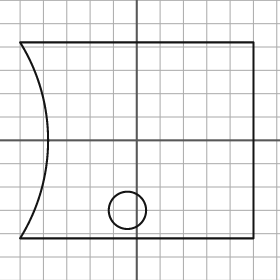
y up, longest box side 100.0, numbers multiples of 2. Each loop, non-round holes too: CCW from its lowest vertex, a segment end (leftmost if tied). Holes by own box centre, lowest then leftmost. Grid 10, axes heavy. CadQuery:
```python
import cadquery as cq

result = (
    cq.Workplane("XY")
    .moveTo(-50.0, -42.0)
    .lineTo(50.0, -42.0)
    .lineTo(50.0, 42.0)
    .lineTo(-50.0, 42.0)
    .threePointArc((-38.0, 0.0), (-50.0, -42.0))
    .close()
    .moveTo(-4.0, -30.0)
    .circle(8.0)
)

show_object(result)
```